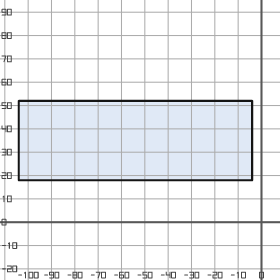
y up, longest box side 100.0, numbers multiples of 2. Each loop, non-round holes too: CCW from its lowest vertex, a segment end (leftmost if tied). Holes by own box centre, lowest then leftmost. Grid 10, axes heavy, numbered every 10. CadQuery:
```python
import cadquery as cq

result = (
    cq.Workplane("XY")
    .moveTo(-104.0, 18.0)
    .lineTo(-4.0, 18.0)
    .lineTo(-4.0, 52.0)
    .lineTo(-104.0, 52.0)
    .close()
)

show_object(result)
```